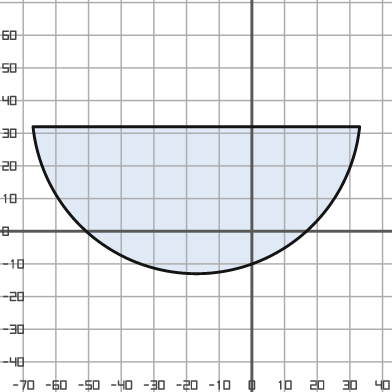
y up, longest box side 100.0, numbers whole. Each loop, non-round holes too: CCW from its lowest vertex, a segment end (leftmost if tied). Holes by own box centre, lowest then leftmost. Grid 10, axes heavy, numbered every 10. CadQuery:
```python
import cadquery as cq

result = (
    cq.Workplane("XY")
    .moveTo(-67.0, 32.0)
    .threePointArc((-17.0, -13.0), (33.0, 32.0))
    .close()
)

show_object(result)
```